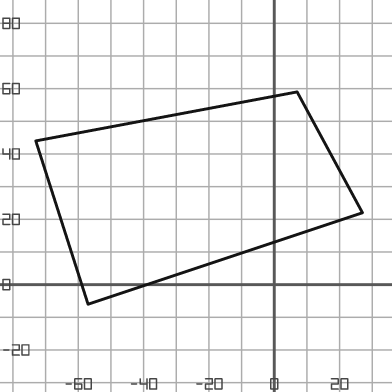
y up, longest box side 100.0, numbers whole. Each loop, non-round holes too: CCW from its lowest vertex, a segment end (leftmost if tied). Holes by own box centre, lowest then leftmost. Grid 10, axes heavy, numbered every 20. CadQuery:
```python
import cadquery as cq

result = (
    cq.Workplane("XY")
    .moveTo(-57.0, -6.0)
    .lineTo(27.0, 22.0)
    .lineTo(7.0, 59.0)
    .lineTo(-73.0, 44.0)
    .close()
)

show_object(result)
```